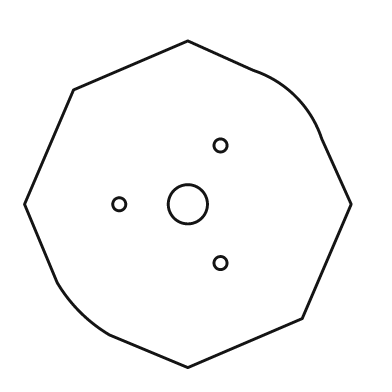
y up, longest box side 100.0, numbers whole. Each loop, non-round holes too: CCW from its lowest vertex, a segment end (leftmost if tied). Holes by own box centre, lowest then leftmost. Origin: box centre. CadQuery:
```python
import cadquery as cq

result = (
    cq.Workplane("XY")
    .moveTo(0.0, -50.0)
    .lineTo(35.0, -35.0)
    .lineTo(50.0, 0.0)
    .lineTo(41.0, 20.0)
    .threePointArc((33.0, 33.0), (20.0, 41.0))
    .lineTo(0.0, 50.0)
    .lineTo(-35.0, 35.0)
    .lineTo(-50.0, 0.0)
    .lineTo(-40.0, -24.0)
    .threePointArc((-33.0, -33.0), (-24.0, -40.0))
    .close()
    .moveTo(10.0, -18.0)
    .circle(2.0)
    .moveTo(-21.0, 0.0)
    .circle(2.0)
    .moveTo(0.0, 0.0)
    .circle(6.0)
    .moveTo(10.0, 18.0)
    .circle(2.0)
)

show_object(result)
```